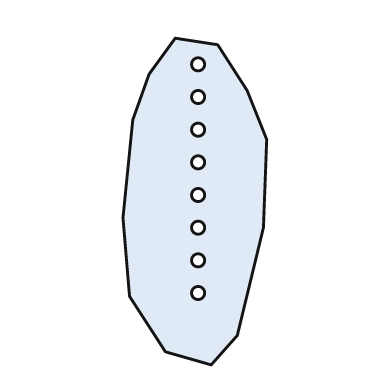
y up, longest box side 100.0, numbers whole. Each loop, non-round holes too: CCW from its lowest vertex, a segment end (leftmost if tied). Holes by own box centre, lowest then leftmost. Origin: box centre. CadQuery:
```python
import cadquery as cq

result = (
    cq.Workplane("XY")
    .moveTo(5.0, -50.0)
    .lineTo(13.0, -41.0)
    .lineTo(21.0, -8.0)
    .lineTo(22.0, 19.0)
    .lineTo(16.0, 34.0)
    .lineTo(7.0, 48.0)
    .lineTo(-6.0, 50.0)
    .lineTo(-14.0, 39.0)
    .lineTo(-19.0, 25.0)
    .lineTo(-22.0, -5.0)
    .lineTo(-20.0, -29.0)
    .lineTo(-9.0, -46.0)
    .close()
    .moveTo(1.0, -28.0)
    .circle(2.0)
    .moveTo(1.0, -18.0)
    .circle(2.0)
    .moveTo(1.0, -8.0)
    .circle(2.0)
    .moveTo(1.0, 2.0)
    .circle(2.0)
    .moveTo(1.0, 12.0)
    .circle(2.0)
    .moveTo(1.0, 22.0)
    .circle(2.0)
    .moveTo(1.0, 32.0)
    .circle(2.0)
    .moveTo(1.0, 42.0)
    .circle(2.0)
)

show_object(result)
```